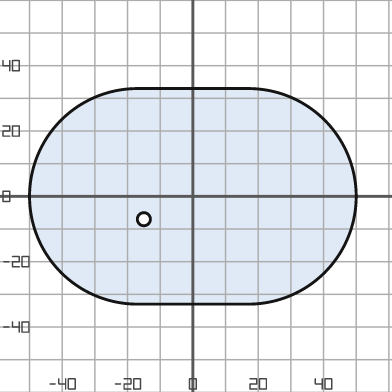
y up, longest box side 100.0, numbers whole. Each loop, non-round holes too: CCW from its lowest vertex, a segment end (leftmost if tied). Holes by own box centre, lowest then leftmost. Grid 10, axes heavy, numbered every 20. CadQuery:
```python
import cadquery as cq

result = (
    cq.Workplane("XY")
    .moveTo(-17.0, -33.0)
    .lineTo(17.0, -33.0)
    .threePointArc((50.0, 0.0), (17.0, 33.0))
    .lineTo(-17.0, 33.0)
    .threePointArc((-50.0, 0.0), (-17.0, -33.0))
    .close()
    .moveTo(-15.0, -7.0)
    .circle(2.0)
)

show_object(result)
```